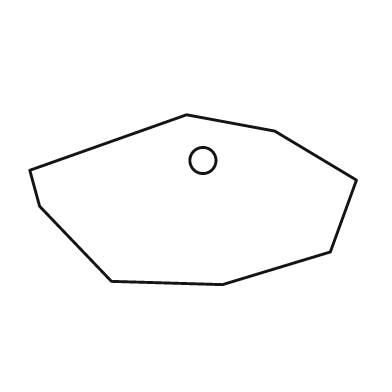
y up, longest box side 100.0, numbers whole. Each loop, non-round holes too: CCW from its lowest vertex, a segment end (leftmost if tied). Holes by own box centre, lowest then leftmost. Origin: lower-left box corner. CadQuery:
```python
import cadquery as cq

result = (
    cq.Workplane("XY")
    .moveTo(59.0, 0.0)
    .lineTo(92.0, 10.0)
    .lineTo(100.0, 32.0)
    .lineTo(75.0, 47.0)
    .lineTo(48.0, 52.0)
    .lineTo(0.0, 35.0)
    .lineTo(3.0, 24.0)
    .lineTo(25.0, 1.0)
    .close()
    .moveTo(53.0, 38.0)
    .circle(4.0)
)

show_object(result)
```